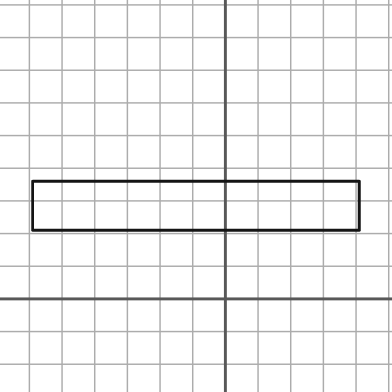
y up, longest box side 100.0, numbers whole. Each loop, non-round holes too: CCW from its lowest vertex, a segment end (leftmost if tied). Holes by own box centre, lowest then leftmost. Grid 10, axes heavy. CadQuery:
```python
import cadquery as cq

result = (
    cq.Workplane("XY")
    .moveTo(-59.0, 21.0)
    .lineTo(41.0, 21.0)
    .lineTo(41.0, 36.0)
    .lineTo(-59.0, 36.0)
    .close()
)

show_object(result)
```